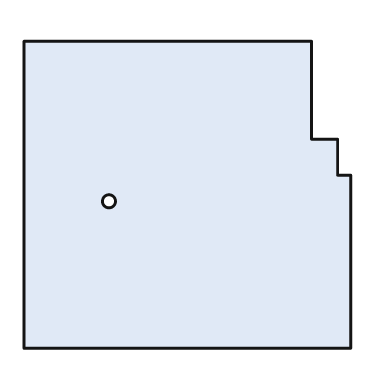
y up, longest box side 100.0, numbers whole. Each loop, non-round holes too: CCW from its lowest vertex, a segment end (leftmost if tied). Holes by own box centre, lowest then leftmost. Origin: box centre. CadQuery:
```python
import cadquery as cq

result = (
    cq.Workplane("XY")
    .moveTo(-50.0, -47.0)
    .lineTo(50.0, -47.0)
    .lineTo(50.0, 6.0)
    .lineTo(46.0, 6.0)
    .lineTo(46.0, 17.0)
    .lineTo(38.0, 17.0)
    .lineTo(38.0, 47.0)
    .lineTo(-50.0, 47.0)
    .close()
    .moveTo(-24.0, -2.0)
    .circle(2.0)
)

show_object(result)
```